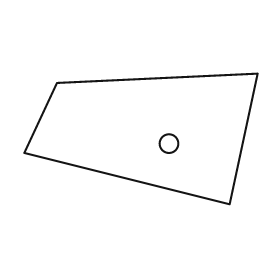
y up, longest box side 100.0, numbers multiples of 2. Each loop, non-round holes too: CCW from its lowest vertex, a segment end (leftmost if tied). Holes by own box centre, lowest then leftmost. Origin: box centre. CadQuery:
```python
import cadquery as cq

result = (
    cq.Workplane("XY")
    .moveTo(38.0, -28.0)
    .lineTo(50.0, 28.0)
    .lineTo(-36.0, 24.0)
    .lineTo(-50.0, -6.0)
    .close()
    .moveTo(12.0, -2.0)
    .circle(4.0)
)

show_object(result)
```